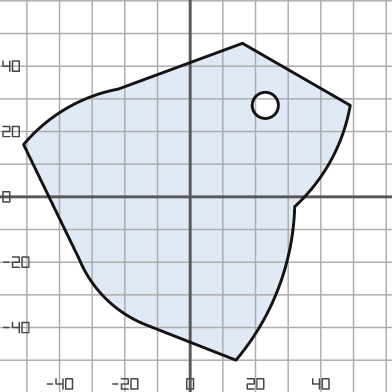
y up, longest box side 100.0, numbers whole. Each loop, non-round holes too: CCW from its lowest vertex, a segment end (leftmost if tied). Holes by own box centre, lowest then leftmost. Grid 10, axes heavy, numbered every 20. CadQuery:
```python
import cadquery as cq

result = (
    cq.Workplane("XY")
    .moveTo(14.0, -50.0)
    .threePointArc((27.0, -28.0), (32.0, -3.0))
    .threePointArc((43.0, 11.0), (49.0, 28.0))
    .lineTo(16.0, 47.0)
    .lineTo(-22.0, 33.0)
    .threePointArc((-38.0, 27.0), (-51.0, 16.0))
    .lineTo(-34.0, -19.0)
    .threePointArc((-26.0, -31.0), (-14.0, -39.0))
    .close()
    .moveTo(23.0, 28.0)
    .circle(4.0)
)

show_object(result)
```